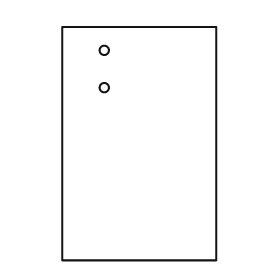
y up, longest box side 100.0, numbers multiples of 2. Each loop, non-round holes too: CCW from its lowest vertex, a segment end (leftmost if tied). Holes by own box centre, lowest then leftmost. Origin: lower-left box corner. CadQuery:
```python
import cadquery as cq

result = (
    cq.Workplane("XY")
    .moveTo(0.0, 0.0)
    .lineTo(66.0, 0.0)
    .lineTo(66.0, 100.0)
    .lineTo(0.0, 100.0)
    .close()
    .moveTo(18.0, 74.0)
    .circle(2.0)
    .moveTo(18.0, 90.0)
    .circle(2.0)
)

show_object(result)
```